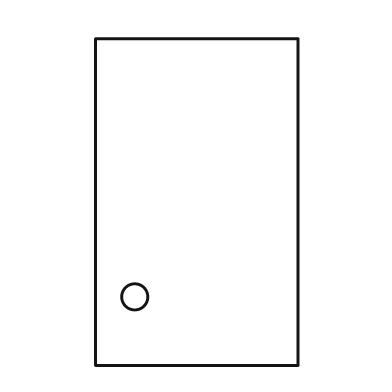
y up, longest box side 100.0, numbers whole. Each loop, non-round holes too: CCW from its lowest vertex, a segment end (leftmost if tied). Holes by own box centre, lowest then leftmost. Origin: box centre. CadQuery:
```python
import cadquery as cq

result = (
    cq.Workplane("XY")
    .moveTo(-31.0, -50.0)
    .lineTo(31.0, -50.0)
    .lineTo(31.0, 50.0)
    .lineTo(-31.0, 50.0)
    .close()
    .moveTo(-19.0, -29.0)
    .circle(4.0)
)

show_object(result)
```